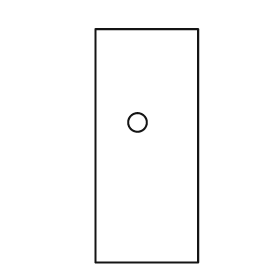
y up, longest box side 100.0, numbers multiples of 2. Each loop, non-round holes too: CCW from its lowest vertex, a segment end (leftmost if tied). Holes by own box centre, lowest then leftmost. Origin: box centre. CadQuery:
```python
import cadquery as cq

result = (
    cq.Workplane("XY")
    .moveTo(-22.0, -50.0)
    .lineTo(22.0, -50.0)
    .lineTo(22.0, 50.0)
    .lineTo(-22.0, 50.0)
    .close()
    .moveTo(-4.0, 10.0)
    .circle(4.0)
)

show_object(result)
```